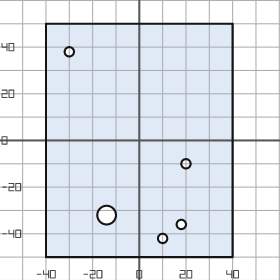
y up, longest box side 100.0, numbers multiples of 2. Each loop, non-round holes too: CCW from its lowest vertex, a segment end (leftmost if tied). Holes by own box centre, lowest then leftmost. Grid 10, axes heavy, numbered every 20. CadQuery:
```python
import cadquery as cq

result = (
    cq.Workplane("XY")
    .moveTo(-40.0, -50.0)
    .lineTo(40.0, -50.0)
    .lineTo(40.0, 50.0)
    .lineTo(-40.0, 50.0)
    .close()
    .moveTo(10.0, -42.0)
    .circle(2.0)
    .moveTo(18.0, -36.0)
    .circle(2.0)
    .moveTo(-14.0, -32.0)
    .circle(4.0)
    .moveTo(20.0, -10.0)
    .circle(2.0)
    .moveTo(-30.0, 38.0)
    .circle(2.0)
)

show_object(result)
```